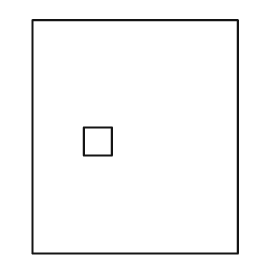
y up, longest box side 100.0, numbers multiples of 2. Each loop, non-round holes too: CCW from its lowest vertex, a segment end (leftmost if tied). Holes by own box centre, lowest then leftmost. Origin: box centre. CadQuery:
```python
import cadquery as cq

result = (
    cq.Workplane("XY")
    .moveTo(-44.0, -50.0)
    .lineTo(44.0, -50.0)
    .lineTo(44.0, 50.0)
    .lineTo(-44.0, 50.0)
    .close()
    .moveTo(-22.0, -8.0)
    .lineTo(-10.0, -8.0)
    .lineTo(-10.0, 4.0)
    .lineTo(-22.0, 4.0)
    .close()
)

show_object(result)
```